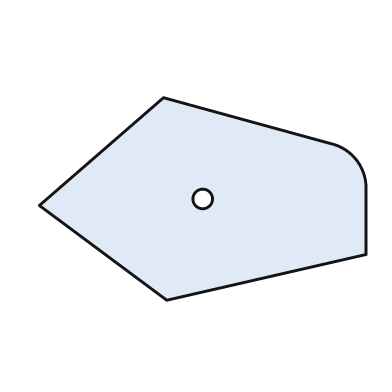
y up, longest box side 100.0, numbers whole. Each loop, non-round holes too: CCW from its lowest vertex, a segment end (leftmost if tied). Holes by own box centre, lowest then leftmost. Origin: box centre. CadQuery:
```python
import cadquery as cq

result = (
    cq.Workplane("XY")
    .moveTo(-11.0, -31.0)
    .lineTo(50.0, -17.0)
    .lineTo(50.0, 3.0)
    .threePointArc((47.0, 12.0), (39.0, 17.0))
    .lineTo(-12.0, 31.0)
    .lineTo(-50.0, -2.0)
    .close()
    .moveTo(0.0, 0.0)
    .circle(3.0)
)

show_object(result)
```